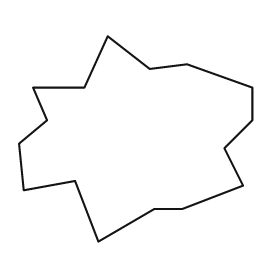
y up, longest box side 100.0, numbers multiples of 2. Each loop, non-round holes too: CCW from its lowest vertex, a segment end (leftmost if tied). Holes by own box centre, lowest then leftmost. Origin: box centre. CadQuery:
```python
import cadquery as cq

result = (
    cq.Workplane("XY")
    .moveTo(-16.0, -44.0)
    .lineTo(8.0, -30.0)
    .lineTo(20.0, -30.0)
    .lineTo(46.0, -20.0)
    .lineTo(38.0, -4.0)
    .lineTo(50.0, 8.0)
    .lineTo(50.0, 22.0)
    .lineTo(22.0, 32.0)
    .lineTo(6.0, 30.0)
    .lineTo(-12.0, 44.0)
    .lineTo(-22.0, 22.0)
    .lineTo(-44.0, 22.0)
    .lineTo(-38.0, 8.0)
    .lineTo(-50.0, -2.0)
    .lineTo(-48.0, -22.0)
    .lineTo(-26.0, -18.0)
    .close()
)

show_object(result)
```